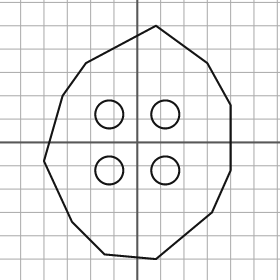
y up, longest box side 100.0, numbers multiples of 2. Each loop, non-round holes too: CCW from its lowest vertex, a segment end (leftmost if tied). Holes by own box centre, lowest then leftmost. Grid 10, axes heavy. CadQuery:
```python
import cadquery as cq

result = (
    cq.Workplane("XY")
    .moveTo(8.0, -50.0)
    .lineTo(32.0, -30.0)
    .lineTo(40.0, -12.0)
    .lineTo(40.0, 16.0)
    .lineTo(30.0, 34.0)
    .lineTo(8.0, 50.0)
    .lineTo(-22.0, 34.0)
    .lineTo(-32.0, 20.0)
    .lineTo(-40.0, -8.0)
    .lineTo(-28.0, -34.0)
    .lineTo(-14.0, -48.0)
    .close()
    .moveTo(-12.0, -12.0)
    .circle(6.0)
    .moveTo(12.0, -12.0)
    .circle(6.0)
    .moveTo(-12.0, 12.0)
    .circle(6.0)
    .moveTo(12.0, 12.0)
    .circle(6.0)
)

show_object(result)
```